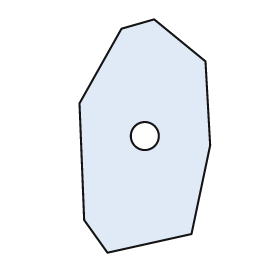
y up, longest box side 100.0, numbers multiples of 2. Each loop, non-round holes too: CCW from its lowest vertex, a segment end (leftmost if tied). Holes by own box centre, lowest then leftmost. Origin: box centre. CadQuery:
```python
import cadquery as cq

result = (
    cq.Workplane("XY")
    .moveTo(-16.0, -50.0)
    .lineTo(20.0, -42.0)
    .lineTo(28.0, -4.0)
    .lineTo(26.0, 32.0)
    .lineTo(4.0, 50.0)
    .lineTo(-10.0, 46.0)
    .lineTo(-28.0, 14.0)
    .lineTo(-26.0, -36.0)
    .close()
    .moveTo(0.0, 0.0)
    .circle(6.0)
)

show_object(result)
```